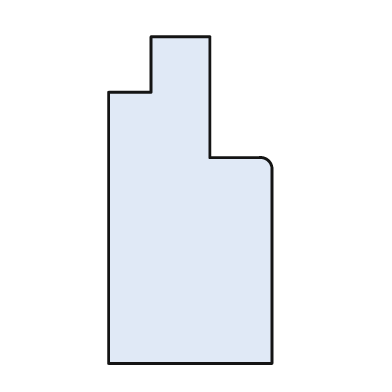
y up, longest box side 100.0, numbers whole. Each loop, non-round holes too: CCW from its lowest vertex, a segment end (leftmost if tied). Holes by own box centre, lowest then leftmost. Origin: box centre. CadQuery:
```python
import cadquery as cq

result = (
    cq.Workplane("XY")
    .moveTo(-25.0, -50.0)
    .lineTo(25.0, -50.0)
    .lineTo(25.0, 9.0)
    .threePointArc((24.0, 12.0), (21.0, 13.0))
    .lineTo(6.0, 13.0)
    .lineTo(6.0, 50.0)
    .lineTo(-12.0, 50.0)
    .lineTo(-12.0, 33.0)
    .lineTo(-25.0, 33.0)
    .close()
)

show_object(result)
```